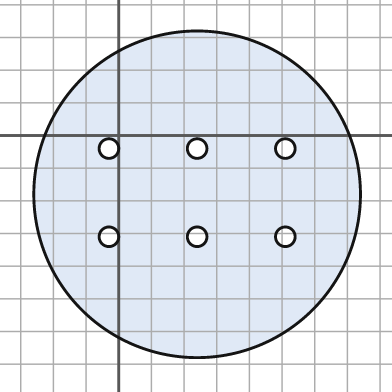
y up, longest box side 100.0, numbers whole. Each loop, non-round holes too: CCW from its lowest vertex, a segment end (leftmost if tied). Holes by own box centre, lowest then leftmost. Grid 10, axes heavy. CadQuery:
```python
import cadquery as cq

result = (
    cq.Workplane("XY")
    .moveTo(24.0, -18.0)
    .circle(50.0)
    .moveTo(-3.0, -31.0)
    .circle(3.0)
    .moveTo(24.0, -31.0)
    .circle(3.0)
    .moveTo(51.0, -31.0)
    .circle(3.0)
    .moveTo(-3.0, -4.0)
    .circle(3.0)
    .moveTo(24.0, -4.0)
    .circle(3.0)
    .moveTo(51.0, -4.0)
    .circle(3.0)
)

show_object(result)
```